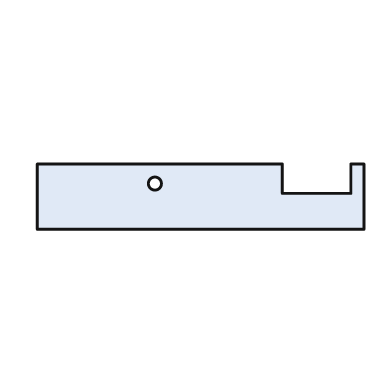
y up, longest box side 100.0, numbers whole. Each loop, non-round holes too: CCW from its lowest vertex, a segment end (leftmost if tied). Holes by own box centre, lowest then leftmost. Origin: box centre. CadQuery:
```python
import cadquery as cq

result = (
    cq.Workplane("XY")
    .moveTo(-50.0, -10.0)
    .lineTo(50.0, -10.0)
    .lineTo(50.0, 10.0)
    .lineTo(46.0, 10.0)
    .lineTo(46.0, 1.0)
    .lineTo(25.0, 1.0)
    .lineTo(25.0, 10.0)
    .lineTo(-50.0, 10.0)
    .close()
    .moveTo(-14.0, 4.0)
    .circle(2.0)
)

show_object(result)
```